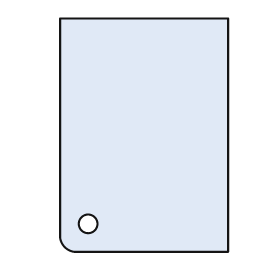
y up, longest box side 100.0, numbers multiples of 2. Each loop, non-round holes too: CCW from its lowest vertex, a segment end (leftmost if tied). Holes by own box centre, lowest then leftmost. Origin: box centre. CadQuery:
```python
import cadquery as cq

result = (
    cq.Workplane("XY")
    .moveTo(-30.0, -50.0)
    .lineTo(36.0, -50.0)
    .lineTo(36.0, 50.0)
    .lineTo(-36.0, 50.0)
    .lineTo(-36.0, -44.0)
    .threePointArc((-34.0, -48.0), (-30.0, -50.0))
    .close()
    .moveTo(-24.0, -38.0)
    .circle(4.0)
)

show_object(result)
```